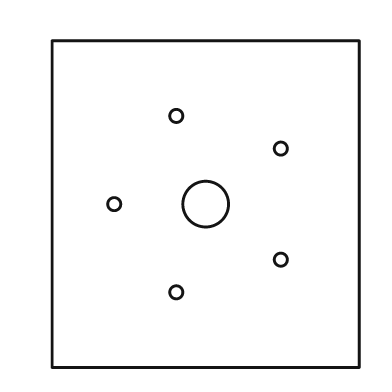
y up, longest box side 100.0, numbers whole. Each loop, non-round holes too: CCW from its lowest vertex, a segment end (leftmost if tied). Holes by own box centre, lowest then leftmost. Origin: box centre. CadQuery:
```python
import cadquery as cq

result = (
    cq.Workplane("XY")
    .moveTo(-47.0, -50.0)
    .lineTo(47.0, -50.0)
    .lineTo(47.0, 50.0)
    .lineTo(-47.0, 50.0)
    .close()
    .moveTo(-9.0, -27.0)
    .circle(2.0)
    .moveTo(23.0, -17.0)
    .circle(2.0)
    .moveTo(-28.0, 0.0)
    .circle(2.0)
    .moveTo(0.0, 0.0)
    .circle(7.0)
    .moveTo(23.0, 17.0)
    .circle(2.0)
    .moveTo(-9.0, 27.0)
    .circle(2.0)
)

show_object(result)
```